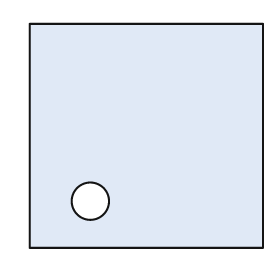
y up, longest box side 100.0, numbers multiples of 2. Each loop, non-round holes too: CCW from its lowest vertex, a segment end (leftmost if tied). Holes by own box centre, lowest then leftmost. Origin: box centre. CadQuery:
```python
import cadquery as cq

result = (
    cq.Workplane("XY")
    .moveTo(-50.0, -48.0)
    .lineTo(50.0, -48.0)
    .lineTo(50.0, 48.0)
    .lineTo(-50.0, 48.0)
    .close()
    .moveTo(-24.0, -28.0)
    .circle(8.0)
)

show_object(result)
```